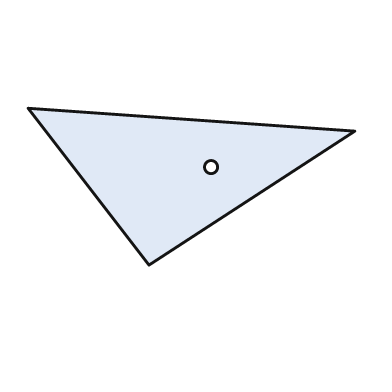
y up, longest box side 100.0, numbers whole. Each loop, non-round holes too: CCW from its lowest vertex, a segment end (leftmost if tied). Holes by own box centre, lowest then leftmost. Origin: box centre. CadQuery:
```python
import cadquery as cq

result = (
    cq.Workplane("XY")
    .moveTo(-13.0, -24.0)
    .lineTo(50.0, 17.0)
    .lineTo(-50.0, 24.0)
    .close()
    .moveTo(6.0, 6.0)
    .circle(2.0)
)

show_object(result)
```